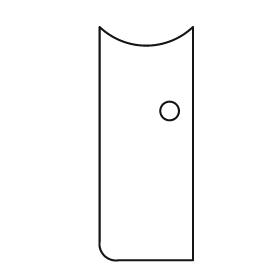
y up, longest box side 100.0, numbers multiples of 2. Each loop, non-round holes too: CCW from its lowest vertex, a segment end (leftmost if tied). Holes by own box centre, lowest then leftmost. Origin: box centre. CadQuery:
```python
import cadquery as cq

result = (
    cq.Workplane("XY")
    .moveTo(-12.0, -50.0)
    .lineTo(20.0, -50.0)
    .lineTo(20.0, 50.0)
    .threePointArc((0.0, 42.0), (-20.0, 50.0))
    .lineTo(-20.0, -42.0)
    .threePointArc((-18.0, -48.0), (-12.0, -50.0))
    .close()
    .moveTo(10.0, 14.0)
    .circle(4.0)
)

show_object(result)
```